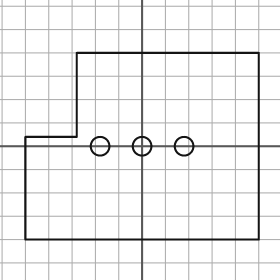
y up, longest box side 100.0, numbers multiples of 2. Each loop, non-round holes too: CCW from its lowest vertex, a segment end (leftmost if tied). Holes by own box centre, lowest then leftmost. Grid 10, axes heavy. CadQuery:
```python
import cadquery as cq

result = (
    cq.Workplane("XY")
    .moveTo(-50.0, -40.0)
    .lineTo(50.0, -40.0)
    .lineTo(50.0, 40.0)
    .lineTo(-28.0, 40.0)
    .lineTo(-28.0, 4.0)
    .lineTo(-50.0, 4.0)
    .close()
    .moveTo(-18.0, 0.0)
    .circle(4.0)
    .moveTo(0.0, 0.0)
    .circle(4.0)
    .moveTo(18.0, 0.0)
    .circle(4.0)
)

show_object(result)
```